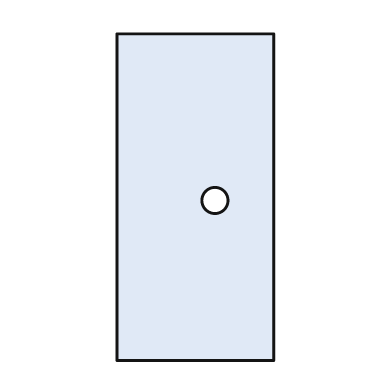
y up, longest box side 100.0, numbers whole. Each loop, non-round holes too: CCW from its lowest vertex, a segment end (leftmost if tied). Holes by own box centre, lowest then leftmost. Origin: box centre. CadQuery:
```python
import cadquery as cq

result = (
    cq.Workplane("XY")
    .moveTo(-24.0, -50.0)
    .lineTo(24.0, -50.0)
    .lineTo(24.0, 50.0)
    .lineTo(-24.0, 50.0)
    .close()
    .moveTo(6.0, -1.0)
    .circle(4.0)
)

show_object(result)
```